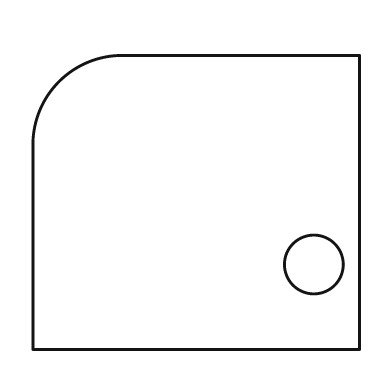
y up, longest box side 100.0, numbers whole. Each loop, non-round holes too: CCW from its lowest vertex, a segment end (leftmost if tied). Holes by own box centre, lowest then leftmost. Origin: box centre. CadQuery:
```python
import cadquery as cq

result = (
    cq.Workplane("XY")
    .moveTo(-50.0, -45.0)
    .lineTo(50.0, -45.0)
    .lineTo(50.0, 45.0)
    .lineTo(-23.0, 45.0)
    .threePointArc((-42.0, 37.0), (-50.0, 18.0))
    .close()
    .moveTo(36.0, -19.0)
    .circle(9.0)
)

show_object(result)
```